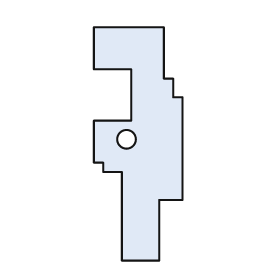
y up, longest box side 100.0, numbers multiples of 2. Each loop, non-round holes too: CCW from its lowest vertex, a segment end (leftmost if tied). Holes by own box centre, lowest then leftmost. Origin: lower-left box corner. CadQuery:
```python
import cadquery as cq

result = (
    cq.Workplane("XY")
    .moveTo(12.0, 0.0)
    .lineTo(28.0, 0.0)
    .lineTo(28.0, 26.0)
    .lineTo(38.0, 26.0)
    .lineTo(38.0, 70.0)
    .lineTo(34.0, 70.0)
    .lineTo(34.0, 78.0)
    .lineTo(30.0, 78.0)
    .lineTo(30.0, 100.0)
    .lineTo(0.0, 100.0)
    .lineTo(0.0, 82.0)
    .lineTo(16.0, 82.0)
    .lineTo(16.0, 60.0)
    .lineTo(0.0, 60.0)
    .lineTo(0.0, 42.0)
    .lineTo(4.0, 42.0)
    .lineTo(4.0, 38.0)
    .lineTo(12.0, 38.0)
    .close()
    .moveTo(14.0, 52.0)
    .circle(4.0)
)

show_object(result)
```